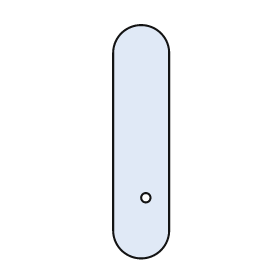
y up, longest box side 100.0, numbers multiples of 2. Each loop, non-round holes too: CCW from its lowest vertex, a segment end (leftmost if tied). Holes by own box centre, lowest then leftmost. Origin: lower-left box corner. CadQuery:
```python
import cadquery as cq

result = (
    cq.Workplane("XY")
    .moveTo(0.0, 12.0)
    .threePointArc((12.0, 0.0), (24.0, 12.0))
    .lineTo(24.0, 88.0)
    .threePointArc((12.0, 100.0), (0.0, 88.0))
    .close()
    .moveTo(14.0, 26.0)
    .circle(2.0)
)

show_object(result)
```